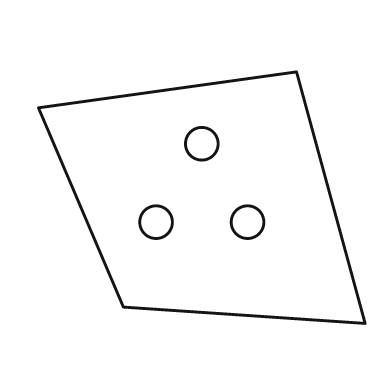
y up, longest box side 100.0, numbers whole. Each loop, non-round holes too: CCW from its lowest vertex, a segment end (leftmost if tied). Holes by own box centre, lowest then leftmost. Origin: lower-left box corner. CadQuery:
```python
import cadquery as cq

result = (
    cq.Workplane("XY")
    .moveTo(100.0, 0.0)
    .lineTo(79.0, 77.0)
    .lineTo(0.0, 66.0)
    .lineTo(26.0, 5.0)
    .close()
    .moveTo(36.0, 31.0)
    .circle(5.0)
    .moveTo(64.0, 31.0)
    .circle(5.0)
    .moveTo(50.0, 55.0)
    .circle(5.0)
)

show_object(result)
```